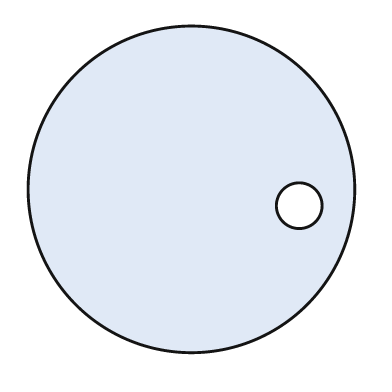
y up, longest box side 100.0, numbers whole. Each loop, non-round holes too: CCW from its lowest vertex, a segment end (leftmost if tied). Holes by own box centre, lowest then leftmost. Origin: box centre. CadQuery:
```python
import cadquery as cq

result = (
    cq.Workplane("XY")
    .moveTo(0.0, 0.0)
    .circle(50.0)
    .moveTo(33.0, -5.0)
    .circle(7.0)
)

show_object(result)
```